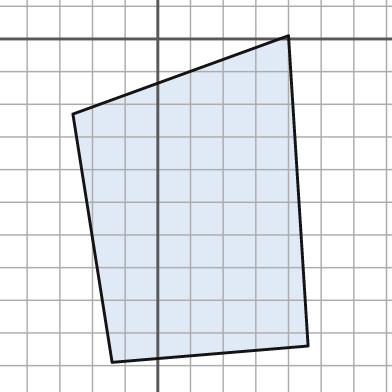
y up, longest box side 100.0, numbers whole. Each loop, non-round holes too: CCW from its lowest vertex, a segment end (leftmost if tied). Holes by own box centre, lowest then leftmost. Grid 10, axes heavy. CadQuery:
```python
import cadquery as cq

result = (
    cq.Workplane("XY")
    .moveTo(-14.0, -99.0)
    .lineTo(46.0, -94.0)
    .lineTo(40.0, 1.0)
    .lineTo(-26.0, -23.0)
    .close()
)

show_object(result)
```